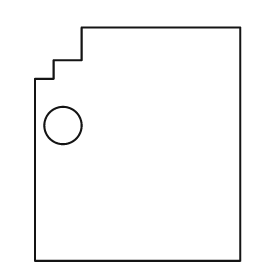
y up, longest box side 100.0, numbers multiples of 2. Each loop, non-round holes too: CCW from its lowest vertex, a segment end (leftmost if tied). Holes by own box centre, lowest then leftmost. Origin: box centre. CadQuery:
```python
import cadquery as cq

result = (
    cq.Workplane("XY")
    .moveTo(-44.0, -50.0)
    .lineTo(44.0, -50.0)
    .lineTo(44.0, 50.0)
    .lineTo(-24.0, 50.0)
    .lineTo(-24.0, 36.0)
    .lineTo(-36.0, 36.0)
    .lineTo(-36.0, 28.0)
    .lineTo(-44.0, 28.0)
    .close()
    .moveTo(-32.0, 8.0)
    .circle(8.0)
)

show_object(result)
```